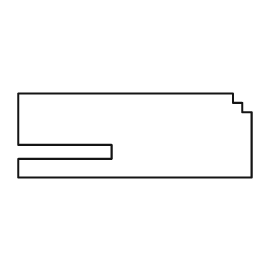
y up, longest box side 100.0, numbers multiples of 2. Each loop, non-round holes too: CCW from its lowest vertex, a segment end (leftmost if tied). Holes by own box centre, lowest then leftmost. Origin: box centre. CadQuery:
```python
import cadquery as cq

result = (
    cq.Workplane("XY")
    .moveTo(-50.0, -18.0)
    .lineTo(50.0, -18.0)
    .lineTo(50.0, 10.0)
    .lineTo(46.0, 10.0)
    .lineTo(46.0, 14.0)
    .lineTo(42.0, 14.0)
    .lineTo(42.0, 18.0)
    .lineTo(-50.0, 18.0)
    .lineTo(-50.0, -4.0)
    .lineTo(-10.0, -4.0)
    .lineTo(-10.0, -10.0)
    .lineTo(-50.0, -10.0)
    .close()
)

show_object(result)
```